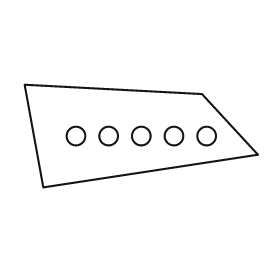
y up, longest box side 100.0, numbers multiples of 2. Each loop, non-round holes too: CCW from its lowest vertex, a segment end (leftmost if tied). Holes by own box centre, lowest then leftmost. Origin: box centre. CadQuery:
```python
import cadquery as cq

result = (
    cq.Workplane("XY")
    .moveTo(-42.0, -22.0)
    .lineTo(50.0, -8.0)
    .lineTo(26.0, 18.0)
    .lineTo(-50.0, 22.0)
    .close()
    .moveTo(-28.0, 0.0)
    .circle(4.0)
    .moveTo(-14.0, 0.0)
    .circle(4.0)
    .moveTo(0.0, 0.0)
    .circle(4.0)
    .moveTo(14.0, 0.0)
    .circle(4.0)
    .moveTo(28.0, 0.0)
    .circle(4.0)
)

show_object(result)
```